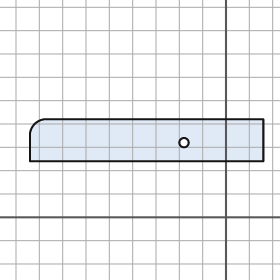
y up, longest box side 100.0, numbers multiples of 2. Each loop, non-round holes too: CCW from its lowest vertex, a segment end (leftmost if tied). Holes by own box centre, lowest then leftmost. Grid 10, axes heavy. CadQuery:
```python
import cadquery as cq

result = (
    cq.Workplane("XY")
    .moveTo(-84.0, 24.0)
    .lineTo(16.0, 24.0)
    .lineTo(16.0, 42.0)
    .lineTo(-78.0, 42.0)
    .threePointArc((-82.0, 40.0), (-84.0, 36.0))
    .close()
    .moveTo(-18.0, 32.0)
    .circle(2.0)
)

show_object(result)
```